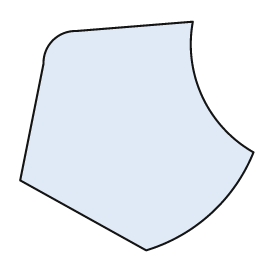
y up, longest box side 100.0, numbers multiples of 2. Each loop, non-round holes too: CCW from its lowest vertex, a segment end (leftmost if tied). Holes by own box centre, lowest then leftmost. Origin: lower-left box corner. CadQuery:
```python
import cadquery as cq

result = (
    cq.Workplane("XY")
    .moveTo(54.0, 0.0)
    .threePointArc((82.0, 16.0), (100.0, 42.0))
    .threePointArc((78.0, 66.0), (74.0, 98.0))
    .lineTo(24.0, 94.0)
    .threePointArc((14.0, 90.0), (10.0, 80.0))
    .lineTo(0.0, 30.0)
    .close()
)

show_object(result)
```